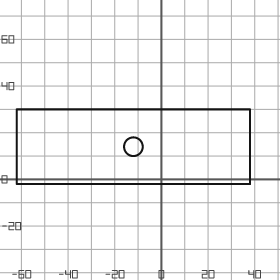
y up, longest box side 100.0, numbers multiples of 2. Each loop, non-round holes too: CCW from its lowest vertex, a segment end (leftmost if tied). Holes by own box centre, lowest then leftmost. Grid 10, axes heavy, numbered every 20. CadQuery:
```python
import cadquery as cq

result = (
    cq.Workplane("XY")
    .moveTo(-62.0, -2.0)
    .lineTo(38.0, -2.0)
    .lineTo(38.0, 30.0)
    .lineTo(-62.0, 30.0)
    .close()
    .moveTo(-12.0, 14.0)
    .circle(4.0)
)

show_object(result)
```